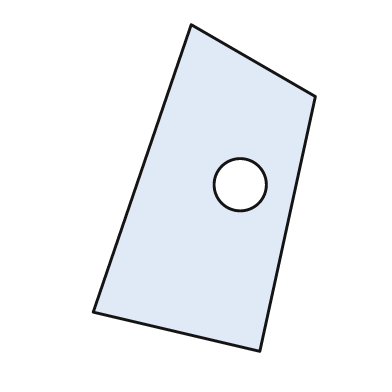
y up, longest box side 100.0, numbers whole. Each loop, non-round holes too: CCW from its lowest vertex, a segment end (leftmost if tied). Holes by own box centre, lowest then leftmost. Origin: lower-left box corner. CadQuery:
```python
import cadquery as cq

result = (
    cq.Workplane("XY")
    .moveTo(51.0, 0.0)
    .lineTo(68.0, 78.0)
    .lineTo(30.0, 100.0)
    .lineTo(0.0, 12.0)
    .close()
    .moveTo(45.0, 51.0)
    .circle(8.0)
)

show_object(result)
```